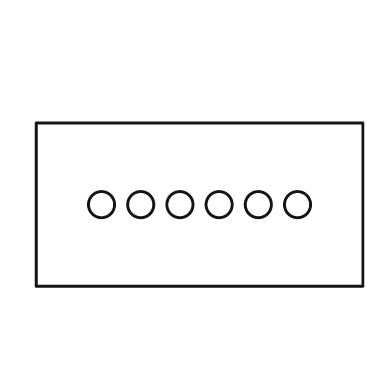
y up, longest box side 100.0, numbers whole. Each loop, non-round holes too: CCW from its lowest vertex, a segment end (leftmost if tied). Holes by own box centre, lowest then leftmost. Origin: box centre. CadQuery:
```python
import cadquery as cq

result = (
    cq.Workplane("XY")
    .moveTo(-50.0, -25.0)
    .lineTo(50.0, -25.0)
    .lineTo(50.0, 25.0)
    .lineTo(-50.0, 25.0)
    .close()
    .moveTo(-30.0, 0.0)
    .circle(4.0)
    .moveTo(-18.0, 0.0)
    .circle(4.0)
    .moveTo(-6.0, 0.0)
    .circle(4.0)
    .moveTo(6.0, 0.0)
    .circle(4.0)
    .moveTo(18.0, 0.0)
    .circle(4.0)
    .moveTo(30.0, 0.0)
    .circle(4.0)
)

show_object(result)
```